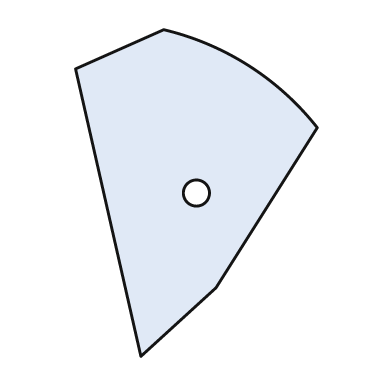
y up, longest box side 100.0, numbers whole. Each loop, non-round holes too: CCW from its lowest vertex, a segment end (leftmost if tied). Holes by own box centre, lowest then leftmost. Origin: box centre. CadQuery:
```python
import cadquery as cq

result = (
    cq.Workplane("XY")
    .moveTo(-17.0, -50.0)
    .lineTo(6.0, -29.0)
    .lineTo(37.0, 20.0)
    .threePointArc((16.0, 39.0), (-10.0, 50.0))
    .lineTo(-37.0, 38.0)
    .close()
    .moveTo(0.0, 0.0)
    .circle(4.0)
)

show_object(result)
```